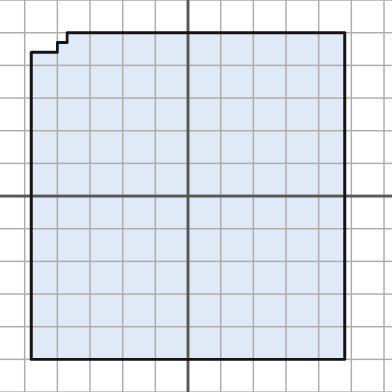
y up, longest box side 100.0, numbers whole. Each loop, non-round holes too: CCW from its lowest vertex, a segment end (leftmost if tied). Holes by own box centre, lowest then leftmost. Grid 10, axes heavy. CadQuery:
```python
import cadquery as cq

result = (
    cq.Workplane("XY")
    .moveTo(-48.0, -50.0)
    .lineTo(48.0, -50.0)
    .lineTo(48.0, 50.0)
    .lineTo(-37.0, 50.0)
    .lineTo(-37.0, 47.0)
    .lineTo(-40.0, 47.0)
    .lineTo(-40.0, 44.0)
    .lineTo(-48.0, 44.0)
    .close()
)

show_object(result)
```